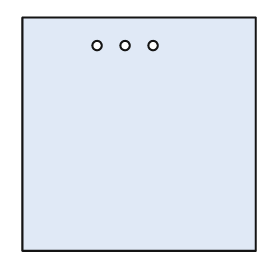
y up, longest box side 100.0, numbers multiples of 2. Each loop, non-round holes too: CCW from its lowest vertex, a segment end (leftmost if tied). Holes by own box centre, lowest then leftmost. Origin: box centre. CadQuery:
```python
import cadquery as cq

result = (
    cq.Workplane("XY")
    .moveTo(-50.0, -50.0)
    .lineTo(50.0, -50.0)
    .lineTo(50.0, 50.0)
    .lineTo(-50.0, 50.0)
    .close()
    .moveTo(-18.0, 38.0)
    .circle(2.0)
    .moveTo(-6.0, 38.0)
    .circle(2.0)
    .moveTo(6.0, 38.0)
    .circle(2.0)
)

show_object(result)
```